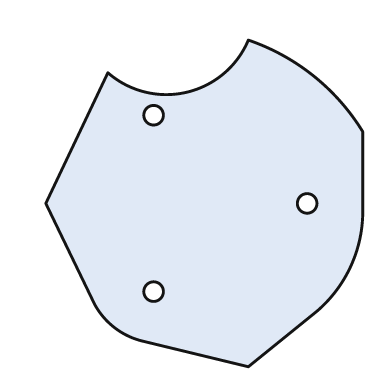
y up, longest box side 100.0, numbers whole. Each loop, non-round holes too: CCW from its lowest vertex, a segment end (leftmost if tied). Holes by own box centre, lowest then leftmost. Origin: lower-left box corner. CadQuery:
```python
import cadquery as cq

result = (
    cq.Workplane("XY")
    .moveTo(62.0, 0.0)
    .lineTo(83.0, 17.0)
    .threePointArc((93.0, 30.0), (97.0, 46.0))
    .lineTo(97.0, 72.0)
    .threePointArc((82.0, 89.0), (62.0, 100.0))
    .threePointArc((43.0, 84.0), (19.0, 90.0))
    .lineTo(0.0, 50.0)
    .lineTo(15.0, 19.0)
    .threePointArc((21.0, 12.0), (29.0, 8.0))
    .close()
    .moveTo(33.0, 23.0)
    .circle(3.0)
    .moveTo(80.0, 50.0)
    .circle(3.0)
    .moveTo(33.0, 77.0)
    .circle(3.0)
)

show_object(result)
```